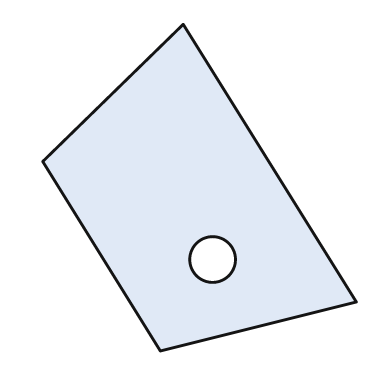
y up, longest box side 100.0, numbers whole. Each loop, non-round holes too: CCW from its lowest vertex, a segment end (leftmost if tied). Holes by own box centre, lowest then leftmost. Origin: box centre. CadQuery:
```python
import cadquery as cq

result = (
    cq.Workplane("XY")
    .moveTo(-12.0, -50.0)
    .lineTo(48.0, -35.0)
    .lineTo(-5.0, 50.0)
    .lineTo(-48.0, 8.0)
    .close()
    .moveTo(4.0, -22.0)
    .circle(7.0)
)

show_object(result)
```